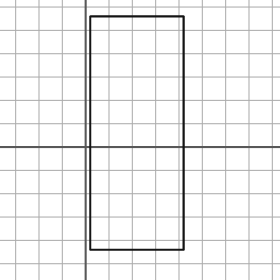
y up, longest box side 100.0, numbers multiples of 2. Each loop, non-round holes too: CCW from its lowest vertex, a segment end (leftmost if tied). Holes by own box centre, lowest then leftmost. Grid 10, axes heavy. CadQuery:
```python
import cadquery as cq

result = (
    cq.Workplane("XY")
    .moveTo(2.0, -44.0)
    .lineTo(42.0, -44.0)
    .lineTo(42.0, 56.0)
    .lineTo(2.0, 56.0)
    .close()
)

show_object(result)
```